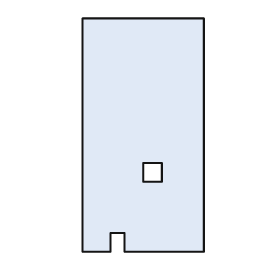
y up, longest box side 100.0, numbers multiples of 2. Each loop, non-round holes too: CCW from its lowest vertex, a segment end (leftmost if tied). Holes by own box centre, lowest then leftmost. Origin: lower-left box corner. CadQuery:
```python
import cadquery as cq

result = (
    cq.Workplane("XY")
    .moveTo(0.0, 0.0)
    .lineTo(12.0, 0.0)
    .lineTo(12.0, 8.0)
    .lineTo(18.0, 8.0)
    .lineTo(18.0, 0.0)
    .lineTo(52.0, 0.0)
    .lineTo(52.0, 100.0)
    .lineTo(0.0, 100.0)
    .close()
    .moveTo(26.0, 30.0)
    .lineTo(34.0, 30.0)
    .lineTo(34.0, 38.0)
    .lineTo(26.0, 38.0)
    .close()
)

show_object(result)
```